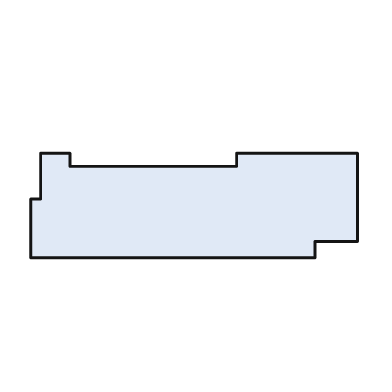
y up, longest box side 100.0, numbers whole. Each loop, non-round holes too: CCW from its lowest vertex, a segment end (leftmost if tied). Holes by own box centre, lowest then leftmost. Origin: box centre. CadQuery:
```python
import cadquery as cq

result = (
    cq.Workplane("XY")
    .moveTo(-50.0, -16.0)
    .lineTo(37.0, -16.0)
    .lineTo(37.0, -11.0)
    .lineTo(50.0, -11.0)
    .lineTo(50.0, 16.0)
    .lineTo(13.0, 16.0)
    .lineTo(13.0, 12.0)
    .lineTo(-38.0, 12.0)
    .lineTo(-38.0, 16.0)
    .lineTo(-47.0, 16.0)
    .lineTo(-47.0, 2.0)
    .lineTo(-50.0, 2.0)
    .close()
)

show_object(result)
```